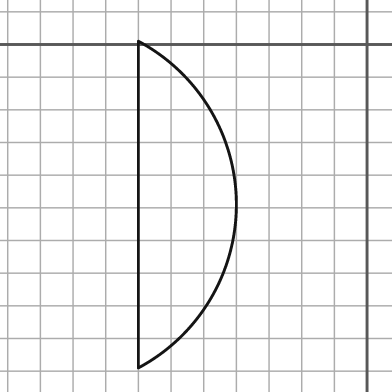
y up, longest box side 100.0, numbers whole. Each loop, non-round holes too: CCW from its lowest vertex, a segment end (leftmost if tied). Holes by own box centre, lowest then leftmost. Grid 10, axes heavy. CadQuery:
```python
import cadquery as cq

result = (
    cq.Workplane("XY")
    .moveTo(-70.0, -99.0)
    .threePointArc((-40.0, -49.0), (-70.0, 1.0))
    .close()
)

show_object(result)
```